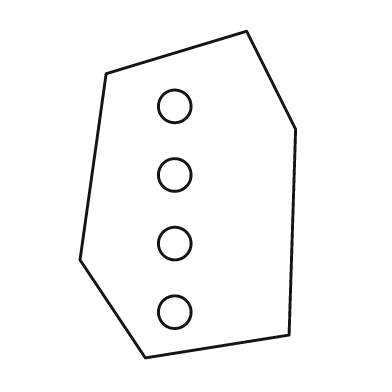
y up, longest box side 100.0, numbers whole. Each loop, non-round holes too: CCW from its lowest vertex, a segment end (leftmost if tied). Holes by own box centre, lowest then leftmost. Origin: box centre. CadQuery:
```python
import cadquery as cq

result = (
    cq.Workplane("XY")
    .moveTo(-13.0, -50.0)
    .lineTo(31.0, -43.0)
    .lineTo(33.0, 20.0)
    .lineTo(18.0, 50.0)
    .lineTo(-25.0, 37.0)
    .lineTo(-33.0, -20.0)
    .close()
    .moveTo(-4.0, -36.0)
    .circle(5.0)
    .moveTo(-4.0, -15.0)
    .circle(5.0)
    .moveTo(-4.0, 6.0)
    .circle(5.0)
    .moveTo(-4.0, 27.0)
    .circle(5.0)
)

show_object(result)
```